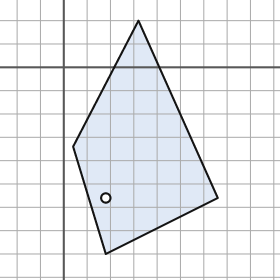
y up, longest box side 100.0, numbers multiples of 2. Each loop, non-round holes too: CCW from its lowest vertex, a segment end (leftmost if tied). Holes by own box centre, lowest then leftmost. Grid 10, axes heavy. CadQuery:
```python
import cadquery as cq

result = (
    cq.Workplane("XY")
    .moveTo(18.0, -80.0)
    .lineTo(66.0, -56.0)
    .lineTo(32.0, 20.0)
    .lineTo(4.0, -34.0)
    .close()
    .moveTo(18.0, -56.0)
    .circle(2.0)
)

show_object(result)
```